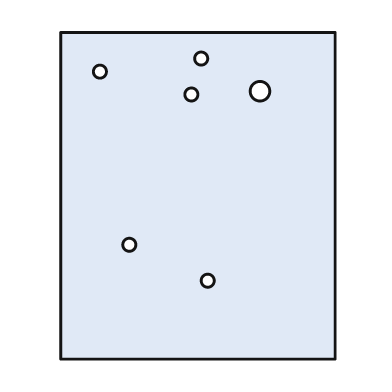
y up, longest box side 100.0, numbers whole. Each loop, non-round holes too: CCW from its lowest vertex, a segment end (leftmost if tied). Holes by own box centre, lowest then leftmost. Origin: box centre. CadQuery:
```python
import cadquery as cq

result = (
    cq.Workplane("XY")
    .moveTo(-42.0, -50.0)
    .lineTo(42.0, -50.0)
    .lineTo(42.0, 50.0)
    .lineTo(-42.0, 50.0)
    .close()
    .moveTo(3.0, -26.0)
    .circle(2.0)
    .moveTo(-21.0, -15.0)
    .circle(2.0)
    .moveTo(-2.0, 31.0)
    .circle(2.0)
    .moveTo(19.0, 32.0)
    .circle(3.0)
    .moveTo(-30.0, 38.0)
    .circle(2.0)
    .moveTo(1.0, 42.0)
    .circle(2.0)
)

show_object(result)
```